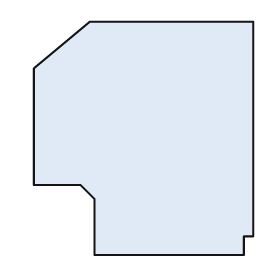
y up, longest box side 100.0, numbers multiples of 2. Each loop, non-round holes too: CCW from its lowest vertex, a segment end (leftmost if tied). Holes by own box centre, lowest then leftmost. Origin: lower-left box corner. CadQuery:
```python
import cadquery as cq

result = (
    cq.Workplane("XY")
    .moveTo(26.0, 0.0)
    .lineTo(90.0, 0.0)
    .lineTo(90.0, 8.0)
    .lineTo(94.0, 8.0)
    .lineTo(94.0, 100.0)
    .lineTo(24.0, 100.0)
    .lineTo(0.0, 80.0)
    .lineTo(0.0, 30.0)
    .lineTo(20.0, 30.0)
    .lineTo(26.0, 24.0)
    .close()
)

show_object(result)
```